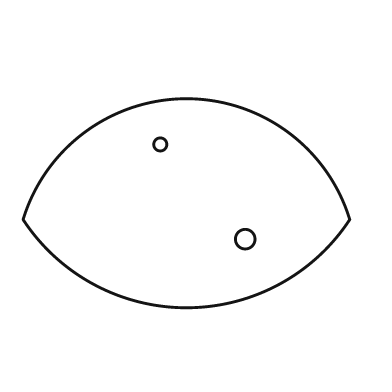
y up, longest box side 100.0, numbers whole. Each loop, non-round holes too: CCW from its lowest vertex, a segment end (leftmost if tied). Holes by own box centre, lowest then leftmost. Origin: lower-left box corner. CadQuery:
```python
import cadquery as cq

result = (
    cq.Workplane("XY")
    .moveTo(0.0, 27.0)
    .threePointArc((50.0, 0.0), (100.0, 27.0))
    .threePointArc((50.0, 64.0), (0.0, 27.0))
    .close()
    .moveTo(68.0, 21.0)
    .circle(3.0)
    .moveTo(42.0, 50.0)
    .circle(2.0)
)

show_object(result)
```